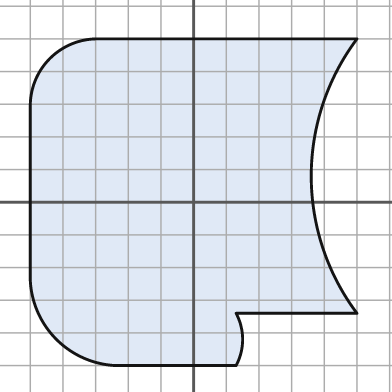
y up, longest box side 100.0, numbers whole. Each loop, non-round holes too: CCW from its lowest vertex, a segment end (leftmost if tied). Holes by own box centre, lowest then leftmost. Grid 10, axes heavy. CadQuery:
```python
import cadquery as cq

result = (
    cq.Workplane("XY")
    .moveTo(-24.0, -50.0)
    .lineTo(13.0, -50.0)
    .threePointArc((15.0, -42.0), (13.0, -34.0))
    .lineTo(50.0, -34.0)
    .threePointArc((36.0, 8.0), (50.0, 50.0))
    .lineTo(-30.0, 50.0)
    .threePointArc((-44.0, 44.0), (-50.0, 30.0))
    .lineTo(-50.0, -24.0)
    .threePointArc((-42.0, -42.0), (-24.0, -50.0))
    .close()
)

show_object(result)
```